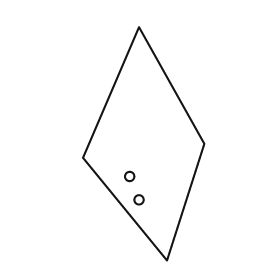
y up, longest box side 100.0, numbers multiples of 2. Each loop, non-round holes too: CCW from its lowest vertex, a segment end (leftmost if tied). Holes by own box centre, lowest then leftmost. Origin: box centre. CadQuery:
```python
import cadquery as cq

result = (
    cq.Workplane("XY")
    .moveTo(10.0, -50.0)
    .lineTo(26.0, 0.0)
    .lineTo(-2.0, 50.0)
    .lineTo(-26.0, -6.0)
    .close()
    .moveTo(-2.0, -24.0)
    .circle(2.0)
    .moveTo(-6.0, -14.0)
    .circle(2.0)
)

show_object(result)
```